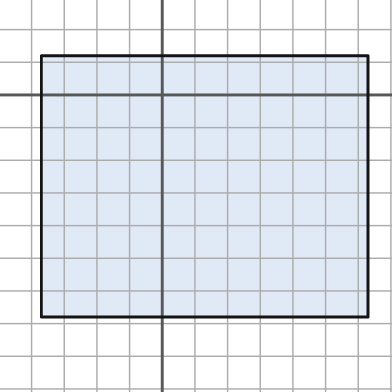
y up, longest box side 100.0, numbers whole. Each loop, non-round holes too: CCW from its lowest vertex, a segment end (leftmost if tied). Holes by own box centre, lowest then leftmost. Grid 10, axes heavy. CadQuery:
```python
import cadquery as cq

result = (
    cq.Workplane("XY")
    .moveTo(-37.0, -68.0)
    .lineTo(63.0, -68.0)
    .lineTo(63.0, 12.0)
    .lineTo(-37.0, 12.0)
    .close()
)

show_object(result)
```